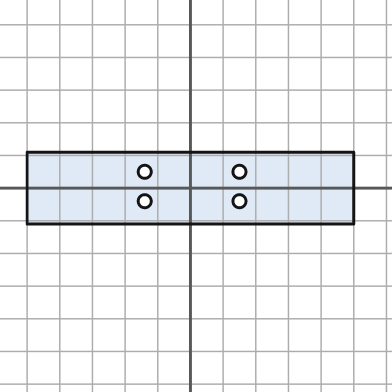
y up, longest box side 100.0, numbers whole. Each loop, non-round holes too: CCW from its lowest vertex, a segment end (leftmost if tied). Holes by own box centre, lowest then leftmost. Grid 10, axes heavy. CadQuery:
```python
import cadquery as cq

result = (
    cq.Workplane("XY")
    .moveTo(-50.0, -11.0)
    .lineTo(50.0, -11.0)
    .lineTo(50.0, 11.0)
    .lineTo(-50.0, 11.0)
    .close()
    .moveTo(-14.0, -4.0)
    .circle(2.0)
    .moveTo(15.0, -4.0)
    .circle(2.0)
    .moveTo(-14.0, 5.0)
    .circle(2.0)
    .moveTo(15.0, 5.0)
    .circle(2.0)
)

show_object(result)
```